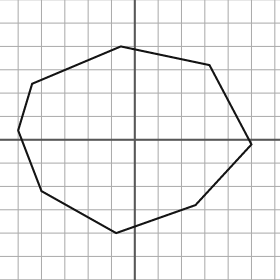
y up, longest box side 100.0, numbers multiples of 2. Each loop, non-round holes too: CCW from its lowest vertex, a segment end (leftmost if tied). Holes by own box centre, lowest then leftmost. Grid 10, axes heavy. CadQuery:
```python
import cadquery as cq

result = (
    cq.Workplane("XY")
    .moveTo(-8.0, -40.0)
    .lineTo(26.0, -28.0)
    .lineTo(50.0, -2.0)
    .lineTo(32.0, 32.0)
    .lineTo(-6.0, 40.0)
    .lineTo(-44.0, 24.0)
    .lineTo(-50.0, 4.0)
    .lineTo(-40.0, -22.0)
    .close()
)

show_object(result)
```